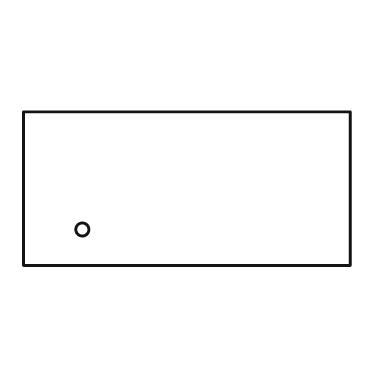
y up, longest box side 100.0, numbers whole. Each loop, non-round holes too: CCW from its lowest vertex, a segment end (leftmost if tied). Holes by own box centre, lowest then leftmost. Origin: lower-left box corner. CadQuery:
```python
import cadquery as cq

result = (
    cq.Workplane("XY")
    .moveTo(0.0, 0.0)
    .lineTo(100.0, 0.0)
    .lineTo(100.0, 47.0)
    .lineTo(0.0, 47.0)
    .close()
    .moveTo(18.0, 11.0)
    .circle(2.0)
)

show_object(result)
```